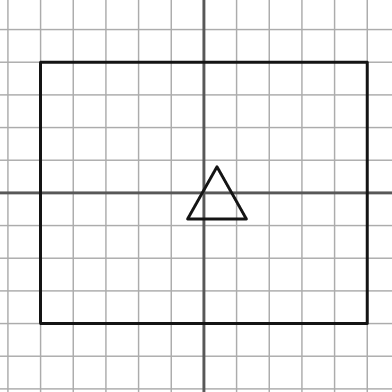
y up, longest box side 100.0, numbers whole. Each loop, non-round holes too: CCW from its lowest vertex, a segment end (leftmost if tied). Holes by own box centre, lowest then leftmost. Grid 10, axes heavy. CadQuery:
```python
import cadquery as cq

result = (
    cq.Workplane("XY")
    .moveTo(-50.0, -40.0)
    .lineTo(50.0, -40.0)
    .lineTo(50.0, 40.0)
    .lineTo(-50.0, 40.0)
    .close()
    .moveTo(-5.0, -8.0)
    .lineTo(13.0, -8.0)
    .lineTo(4.0, 8.0)
    .close()
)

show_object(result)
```